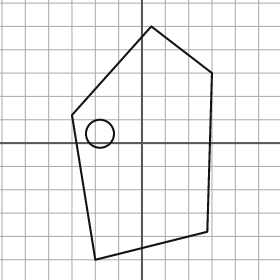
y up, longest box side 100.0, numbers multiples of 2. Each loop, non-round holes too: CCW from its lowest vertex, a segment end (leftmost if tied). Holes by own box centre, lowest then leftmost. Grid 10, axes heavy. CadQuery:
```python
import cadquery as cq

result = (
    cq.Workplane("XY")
    .moveTo(-20.0, -50.0)
    .lineTo(28.0, -38.0)
    .lineTo(30.0, 30.0)
    .lineTo(4.0, 50.0)
    .lineTo(-30.0, 12.0)
    .close()
    .moveTo(-18.0, 4.0)
    .circle(6.0)
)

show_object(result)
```